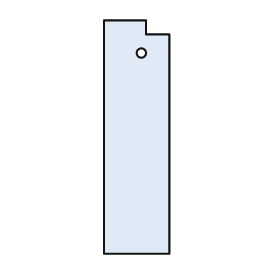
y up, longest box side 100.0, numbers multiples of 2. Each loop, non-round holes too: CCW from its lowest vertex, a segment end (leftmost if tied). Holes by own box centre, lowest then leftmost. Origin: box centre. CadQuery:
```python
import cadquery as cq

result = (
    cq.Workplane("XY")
    .moveTo(-14.0, -50.0)
    .lineTo(14.0, -50.0)
    .lineTo(14.0, 44.0)
    .lineTo(4.0, 44.0)
    .lineTo(4.0, 50.0)
    .lineTo(-14.0, 50.0)
    .close()
    .moveTo(2.0, 36.0)
    .circle(2.0)
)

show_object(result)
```